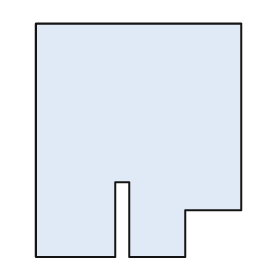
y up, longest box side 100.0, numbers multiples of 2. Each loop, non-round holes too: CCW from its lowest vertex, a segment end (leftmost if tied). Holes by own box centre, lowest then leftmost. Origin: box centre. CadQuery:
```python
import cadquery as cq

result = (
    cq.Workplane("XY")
    .moveTo(-44.0, -50.0)
    .lineTo(-10.0, -50.0)
    .lineTo(-10.0, -18.0)
    .lineTo(-4.0, -18.0)
    .lineTo(-4.0, -50.0)
    .lineTo(20.0, -50.0)
    .lineTo(20.0, -30.0)
    .lineTo(44.0, -30.0)
    .lineTo(44.0, 50.0)
    .lineTo(-44.0, 50.0)
    .close()
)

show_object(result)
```